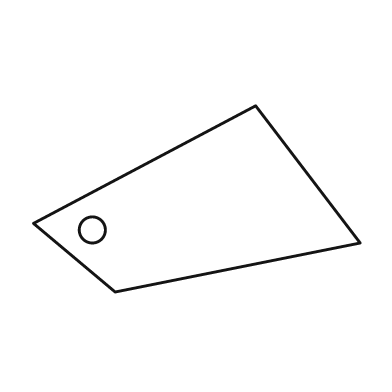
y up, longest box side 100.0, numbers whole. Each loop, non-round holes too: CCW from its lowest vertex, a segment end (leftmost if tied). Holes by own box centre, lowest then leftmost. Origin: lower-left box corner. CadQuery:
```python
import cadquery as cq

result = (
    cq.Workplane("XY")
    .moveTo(25.0, 0.0)
    .lineTo(100.0, 15.0)
    .lineTo(68.0, 57.0)
    .lineTo(0.0, 21.0)
    .close()
    .moveTo(18.0, 19.0)
    .circle(4.0)
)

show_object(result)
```